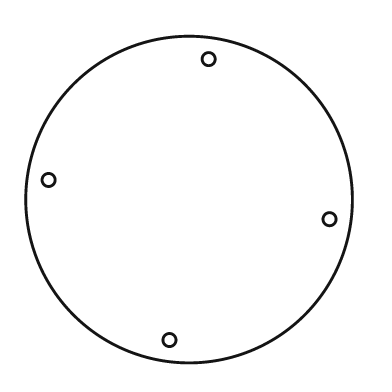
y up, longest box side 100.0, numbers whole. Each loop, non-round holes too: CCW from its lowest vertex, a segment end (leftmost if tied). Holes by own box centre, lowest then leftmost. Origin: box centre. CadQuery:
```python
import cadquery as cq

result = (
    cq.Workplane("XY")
    .moveTo(0.0, 0.0)
    .circle(50.0)
    .moveTo(-6.0, -43.0)
    .circle(2.0)
    .moveTo(43.0, -6.0)
    .circle(2.0)
    .moveTo(-43.0, 6.0)
    .circle(2.0)
    .moveTo(6.0, 43.0)
    .circle(2.0)
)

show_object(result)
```